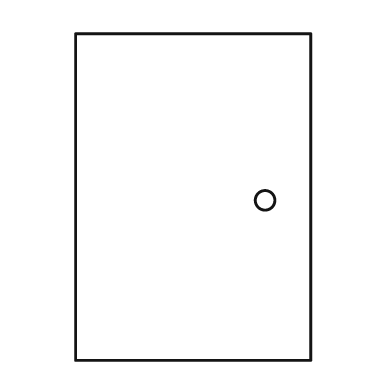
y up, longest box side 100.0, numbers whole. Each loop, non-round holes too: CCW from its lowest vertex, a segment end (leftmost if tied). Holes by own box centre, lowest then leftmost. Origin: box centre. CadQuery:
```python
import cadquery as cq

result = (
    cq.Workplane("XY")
    .moveTo(-36.0, -50.0)
    .lineTo(36.0, -50.0)
    .lineTo(36.0, 50.0)
    .lineTo(-36.0, 50.0)
    .close()
    .moveTo(22.0, -1.0)
    .circle(3.0)
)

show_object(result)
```